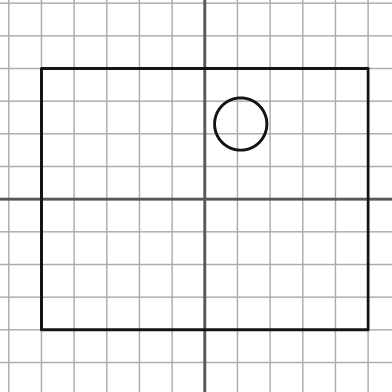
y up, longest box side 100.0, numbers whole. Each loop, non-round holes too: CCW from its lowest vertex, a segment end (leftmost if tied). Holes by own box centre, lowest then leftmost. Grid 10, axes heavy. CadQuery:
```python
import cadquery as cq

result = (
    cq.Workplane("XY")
    .moveTo(-50.0, -40.0)
    .lineTo(50.0, -40.0)
    .lineTo(50.0, 40.0)
    .lineTo(-50.0, 40.0)
    .close()
    .moveTo(11.0, 23.0)
    .circle(8.0)
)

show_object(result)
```